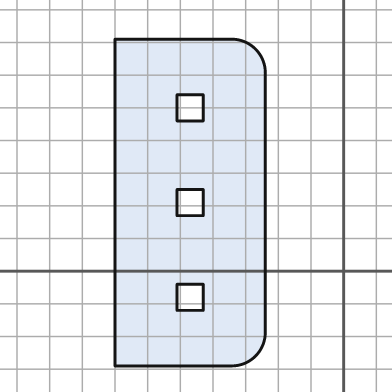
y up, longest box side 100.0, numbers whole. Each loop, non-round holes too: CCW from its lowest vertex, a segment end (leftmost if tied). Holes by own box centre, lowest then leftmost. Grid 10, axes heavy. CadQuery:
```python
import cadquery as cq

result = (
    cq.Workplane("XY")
    .moveTo(-70.0, -29.0)
    .lineTo(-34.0, -29.0)
    .threePointArc((-27.0, -26.0), (-24.0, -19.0))
    .lineTo(-24.0, 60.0)
    .threePointArc((-27.0, 68.0), (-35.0, 71.0))
    .lineTo(-70.0, 71.0)
    .close()
    .moveTo(-51.0, -12.0)
    .lineTo(-43.0, -12.0)
    .lineTo(-43.0, -4.0)
    .lineTo(-51.0, -4.0)
    .close()
    .moveTo(-51.0, 17.0)
    .lineTo(-43.0, 17.0)
    .lineTo(-43.0, 25.0)
    .lineTo(-51.0, 25.0)
    .close()
    .moveTo(-51.0, 46.0)
    .lineTo(-43.0, 46.0)
    .lineTo(-43.0, 54.0)
    .lineTo(-51.0, 54.0)
    .close()
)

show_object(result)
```